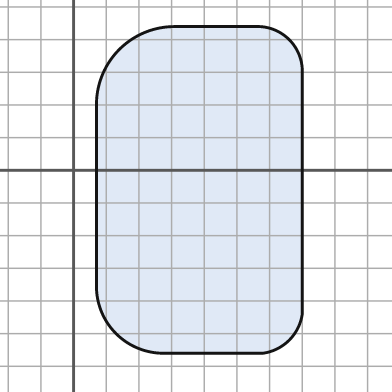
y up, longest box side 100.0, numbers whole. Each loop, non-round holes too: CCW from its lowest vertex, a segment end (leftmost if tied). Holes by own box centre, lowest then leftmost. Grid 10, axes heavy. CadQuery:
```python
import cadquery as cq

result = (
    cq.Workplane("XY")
    .moveTo(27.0, -56.0)
    .lineTo(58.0, -56.0)
    .threePointArc((66.0, -52.0), (70.0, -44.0))
    .lineTo(70.0, 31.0)
    .threePointArc((66.0, 40.0), (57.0, 44.0))
    .lineTo(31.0, 44.0)
    .threePointArc((14.0, 37.0), (7.0, 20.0))
    .lineTo(7.0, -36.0)
    .threePointArc((13.0, -50.0), (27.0, -56.0))
    .close()
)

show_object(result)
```